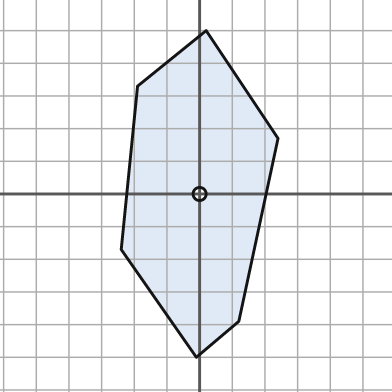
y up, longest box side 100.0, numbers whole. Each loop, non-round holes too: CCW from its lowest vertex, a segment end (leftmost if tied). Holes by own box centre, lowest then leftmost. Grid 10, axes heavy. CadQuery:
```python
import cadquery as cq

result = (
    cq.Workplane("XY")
    .moveTo(-1.0, -50.0)
    .lineTo(12.0, -39.0)
    .lineTo(24.0, 17.0)
    .lineTo(2.0, 50.0)
    .lineTo(-19.0, 33.0)
    .lineTo(-24.0, -17.0)
    .close()
    .moveTo(0.0, 0.0)
    .circle(2.0)
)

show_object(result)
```